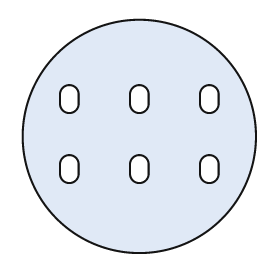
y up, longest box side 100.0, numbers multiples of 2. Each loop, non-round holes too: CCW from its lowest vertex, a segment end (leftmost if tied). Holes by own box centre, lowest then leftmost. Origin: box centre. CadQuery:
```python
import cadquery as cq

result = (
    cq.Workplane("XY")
    .moveTo(0.0, 0.0)
    .circle(50.0)
    .moveTo(-34.0, -16.0)
    .threePointArc((-30.0, -20.0), (-26.0, -16.0))
    .lineTo(-26.0, -12.0)
    .threePointArc((-30.0, -8.0), (-34.0, -12.0))
    .close()
    .moveTo(-4.0, -16.0)
    .threePointArc((0.0, -20.0), (4.0, -16.0))
    .lineTo(4.0, -12.0)
    .threePointArc((0.0, -8.0), (-4.0, -12.0))
    .close()
    .moveTo(26.0, -16.0)
    .threePointArc((30.0, -20.0), (34.0, -16.0))
    .lineTo(34.0, -12.0)
    .threePointArc((30.0, -8.0), (26.0, -12.0))
    .close()
    .moveTo(-34.0, 14.0)
    .threePointArc((-30.0, 10.0), (-26.0, 14.0))
    .lineTo(-26.0, 18.0)
    .threePointArc((-30.0, 22.0), (-34.0, 18.0))
    .close()
    .moveTo(-4.0, 14.0)
    .threePointArc((0.0, 10.0), (4.0, 14.0))
    .lineTo(4.0, 18.0)
    .threePointArc((0.0, 22.0), (-4.0, 18.0))
    .close()
    .moveTo(26.0, 14.0)
    .threePointArc((30.0, 10.0), (34.0, 14.0))
    .lineTo(34.0, 18.0)
    .threePointArc((30.0, 22.0), (26.0, 18.0))
    .close()
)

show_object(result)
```